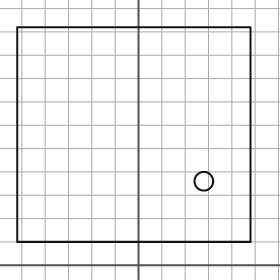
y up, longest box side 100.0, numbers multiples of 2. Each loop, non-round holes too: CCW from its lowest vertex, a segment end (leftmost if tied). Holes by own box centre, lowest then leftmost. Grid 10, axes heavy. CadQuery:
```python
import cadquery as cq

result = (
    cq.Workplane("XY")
    .moveTo(-52.0, 10.0)
    .lineTo(48.0, 10.0)
    .lineTo(48.0, 102.0)
    .lineTo(-52.0, 102.0)
    .close()
    .moveTo(28.0, 36.0)
    .circle(4.0)
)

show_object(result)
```